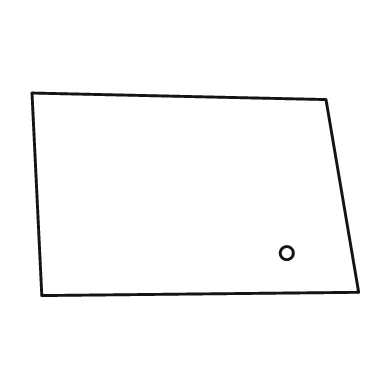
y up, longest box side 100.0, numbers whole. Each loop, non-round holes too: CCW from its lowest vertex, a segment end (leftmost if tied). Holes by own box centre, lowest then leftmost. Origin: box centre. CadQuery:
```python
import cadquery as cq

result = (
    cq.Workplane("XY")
    .moveTo(-47.0, -31.0)
    .lineTo(50.0, -30.0)
    .lineTo(40.0, 29.0)
    .lineTo(-50.0, 31.0)
    .close()
    .moveTo(28.0, -18.0)
    .circle(2.0)
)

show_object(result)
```